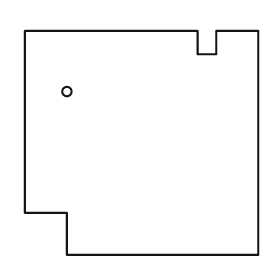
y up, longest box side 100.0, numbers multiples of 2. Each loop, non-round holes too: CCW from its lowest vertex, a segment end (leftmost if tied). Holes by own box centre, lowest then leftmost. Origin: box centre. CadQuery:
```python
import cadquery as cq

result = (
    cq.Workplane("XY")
    .moveTo(-32.0, -48.0)
    .lineTo(50.0, -48.0)
    .lineTo(50.0, 48.0)
    .lineTo(32.0, 48.0)
    .lineTo(32.0, 38.0)
    .lineTo(24.0, 38.0)
    .lineTo(24.0, 48.0)
    .lineTo(-50.0, 48.0)
    .lineTo(-50.0, -30.0)
    .lineTo(-32.0, -30.0)
    .close()
    .moveTo(-32.0, 22.0)
    .circle(2.0)
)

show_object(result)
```